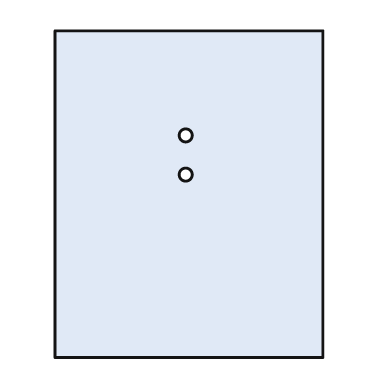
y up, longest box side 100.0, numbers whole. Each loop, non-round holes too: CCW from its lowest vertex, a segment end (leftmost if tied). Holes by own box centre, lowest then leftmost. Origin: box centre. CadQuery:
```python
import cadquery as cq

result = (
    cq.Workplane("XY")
    .moveTo(-41.0, -50.0)
    .lineTo(41.0, -50.0)
    .lineTo(41.0, 50.0)
    .lineTo(-41.0, 50.0)
    .close()
    .moveTo(-1.0, 6.0)
    .circle(2.0)
    .moveTo(-1.0, 18.0)
    .circle(2.0)
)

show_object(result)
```